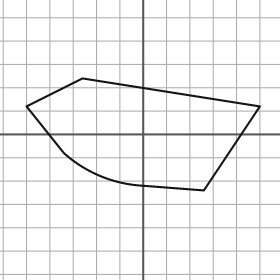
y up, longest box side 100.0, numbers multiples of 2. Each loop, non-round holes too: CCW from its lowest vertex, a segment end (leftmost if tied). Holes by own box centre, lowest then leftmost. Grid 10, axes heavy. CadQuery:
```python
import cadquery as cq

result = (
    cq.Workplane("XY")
    .moveTo(26.0, -24.0)
    .lineTo(50.0, 12.0)
    .lineTo(-26.0, 24.0)
    .lineTo(-50.0, 12.0)
    .lineTo(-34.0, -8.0)
    .threePointArc((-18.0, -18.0), (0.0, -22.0))
    .close()
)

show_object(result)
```